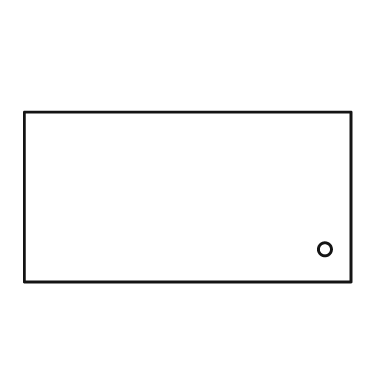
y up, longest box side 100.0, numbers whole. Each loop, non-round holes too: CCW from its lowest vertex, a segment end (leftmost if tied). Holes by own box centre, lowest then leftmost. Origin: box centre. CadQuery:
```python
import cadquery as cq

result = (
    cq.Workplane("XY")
    .moveTo(-50.0, -26.0)
    .lineTo(50.0, -26.0)
    .lineTo(50.0, 26.0)
    .lineTo(-50.0, 26.0)
    .close()
    .moveTo(42.0, -16.0)
    .circle(2.0)
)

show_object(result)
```